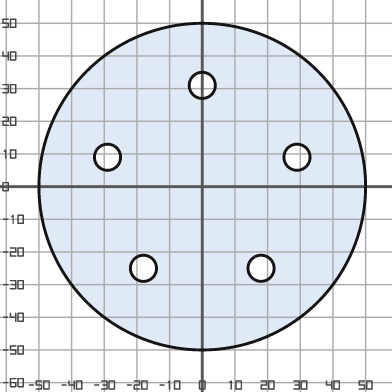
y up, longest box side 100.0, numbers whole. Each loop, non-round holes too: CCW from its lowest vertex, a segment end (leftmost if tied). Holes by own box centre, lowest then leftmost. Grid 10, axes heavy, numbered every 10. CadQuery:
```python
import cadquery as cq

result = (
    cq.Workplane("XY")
    .moveTo(0.0, 0.0)
    .circle(50.0)
    .moveTo(-18.0, -25.0)
    .circle(4.0)
    .moveTo(18.0, -25.0)
    .circle(4.0)
    .moveTo(-29.0, 9.0)
    .circle(4.0)
    .moveTo(29.0, 9.0)
    .circle(4.0)
    .moveTo(0.0, 31.0)
    .circle(4.0)
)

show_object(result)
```